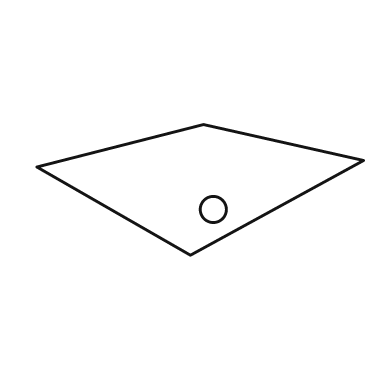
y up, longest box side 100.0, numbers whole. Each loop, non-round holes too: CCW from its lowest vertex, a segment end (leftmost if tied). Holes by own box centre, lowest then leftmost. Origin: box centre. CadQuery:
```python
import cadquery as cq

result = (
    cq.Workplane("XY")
    .moveTo(-3.0, -20.0)
    .lineTo(50.0, 9.0)
    .lineTo(1.0, 20.0)
    .lineTo(-50.0, 7.0)
    .close()
    .moveTo(4.0, -6.0)
    .circle(4.0)
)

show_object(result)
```